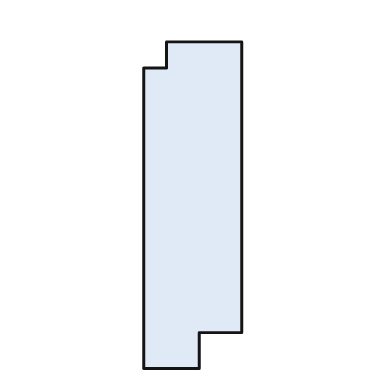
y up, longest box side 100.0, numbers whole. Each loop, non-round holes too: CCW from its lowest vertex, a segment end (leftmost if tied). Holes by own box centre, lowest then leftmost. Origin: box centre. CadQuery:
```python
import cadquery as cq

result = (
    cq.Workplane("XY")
    .moveTo(-15.0, -50.0)
    .lineTo(2.0, -50.0)
    .lineTo(2.0, -39.0)
    .lineTo(15.0, -39.0)
    .lineTo(15.0, 50.0)
    .lineTo(-8.0, 50.0)
    .lineTo(-8.0, 42.0)
    .lineTo(-15.0, 42.0)
    .close()
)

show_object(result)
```